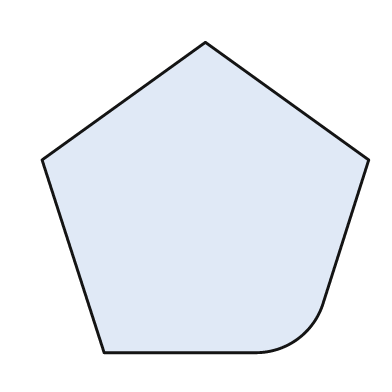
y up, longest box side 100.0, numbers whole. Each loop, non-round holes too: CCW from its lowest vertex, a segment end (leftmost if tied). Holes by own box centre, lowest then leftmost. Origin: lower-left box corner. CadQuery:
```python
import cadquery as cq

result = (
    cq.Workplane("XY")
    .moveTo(19.0, 0.0)
    .lineTo(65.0, 0.0)
    .threePointArc((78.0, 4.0), (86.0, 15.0))
    .lineTo(100.0, 59.0)
    .lineTo(50.0, 95.0)
    .lineTo(0.0, 59.0)
    .close()
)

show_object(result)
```